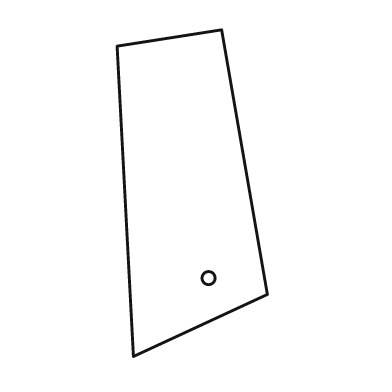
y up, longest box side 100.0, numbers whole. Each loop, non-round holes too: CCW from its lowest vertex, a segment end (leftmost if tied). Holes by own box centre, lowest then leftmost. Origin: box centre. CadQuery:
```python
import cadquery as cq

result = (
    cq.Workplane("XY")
    .moveTo(-18.0, -50.0)
    .lineTo(23.0, -31.0)
    .lineTo(9.0, 50.0)
    .lineTo(-23.0, 45.0)
    .close()
    .moveTo(5.0, -26.0)
    .circle(2.0)
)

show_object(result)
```